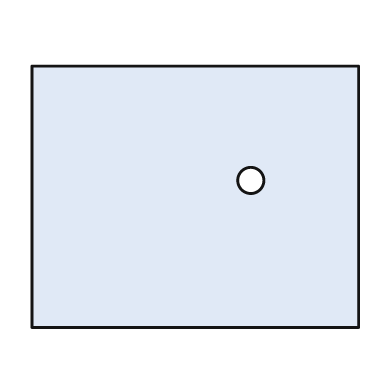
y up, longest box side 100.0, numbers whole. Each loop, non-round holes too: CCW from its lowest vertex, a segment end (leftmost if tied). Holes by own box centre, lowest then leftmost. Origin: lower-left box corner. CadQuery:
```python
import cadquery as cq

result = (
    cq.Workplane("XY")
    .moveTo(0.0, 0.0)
    .lineTo(100.0, 0.0)
    .lineTo(100.0, 80.0)
    .lineTo(0.0, 80.0)
    .close()
    .moveTo(67.0, 45.0)
    .circle(4.0)
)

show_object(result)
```